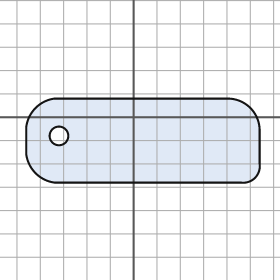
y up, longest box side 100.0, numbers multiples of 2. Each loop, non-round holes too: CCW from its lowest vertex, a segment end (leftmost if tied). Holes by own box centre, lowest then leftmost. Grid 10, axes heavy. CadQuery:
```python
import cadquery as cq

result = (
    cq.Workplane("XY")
    .moveTo(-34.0, -28.0)
    .lineTo(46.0, -28.0)
    .threePointArc((52.0, -26.0), (54.0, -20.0))
    .lineTo(54.0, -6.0)
    .threePointArc((50.0, 4.0), (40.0, 8.0))
    .lineTo(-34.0, 8.0)
    .threePointArc((-42.0, 4.0), (-46.0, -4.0))
    .lineTo(-46.0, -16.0)
    .threePointArc((-42.0, -24.0), (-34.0, -28.0))
    .close()
    .moveTo(-32.0, -8.0)
    .circle(4.0)
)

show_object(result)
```